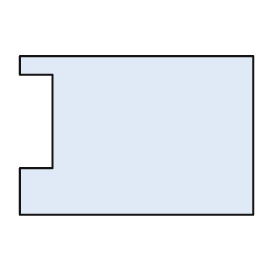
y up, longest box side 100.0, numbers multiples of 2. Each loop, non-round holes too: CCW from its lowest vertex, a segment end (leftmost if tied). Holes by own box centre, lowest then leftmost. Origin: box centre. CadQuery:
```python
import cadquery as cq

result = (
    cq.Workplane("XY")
    .moveTo(-50.0, -34.0)
    .lineTo(50.0, -34.0)
    .lineTo(50.0, 34.0)
    .lineTo(-50.0, 34.0)
    .lineTo(-50.0, 26.0)
    .lineTo(-36.0, 26.0)
    .lineTo(-36.0, -14.0)
    .lineTo(-50.0, -14.0)
    .close()
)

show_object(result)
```